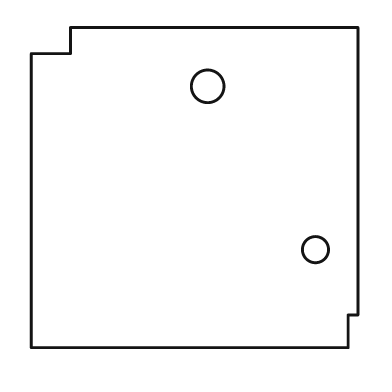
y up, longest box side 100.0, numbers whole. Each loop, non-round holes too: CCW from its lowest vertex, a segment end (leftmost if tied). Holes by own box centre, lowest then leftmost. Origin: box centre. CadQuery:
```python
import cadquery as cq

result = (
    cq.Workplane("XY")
    .moveTo(-50.0, -49.0)
    .lineTo(47.0, -49.0)
    .lineTo(47.0, -39.0)
    .lineTo(50.0, -39.0)
    .lineTo(50.0, 49.0)
    .lineTo(-38.0, 49.0)
    .lineTo(-38.0, 41.0)
    .lineTo(-50.0, 41.0)
    .close()
    .moveTo(37.0, -19.0)
    .circle(4.0)
    .moveTo(4.0, 31.0)
    .circle(5.0)
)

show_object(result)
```